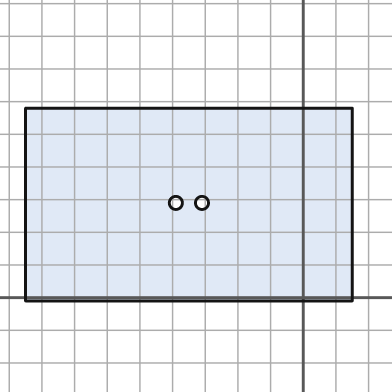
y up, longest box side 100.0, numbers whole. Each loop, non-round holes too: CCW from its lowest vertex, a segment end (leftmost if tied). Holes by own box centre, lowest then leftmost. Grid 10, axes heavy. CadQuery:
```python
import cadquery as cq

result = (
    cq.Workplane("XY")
    .moveTo(-85.0, -1.0)
    .lineTo(15.0, -1.0)
    .lineTo(15.0, 58.0)
    .lineTo(-85.0, 58.0)
    .close()
    .moveTo(-39.0, 29.0)
    .circle(2.0)
    .moveTo(-31.0, 29.0)
    .circle(2.0)
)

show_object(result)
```